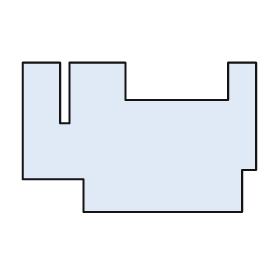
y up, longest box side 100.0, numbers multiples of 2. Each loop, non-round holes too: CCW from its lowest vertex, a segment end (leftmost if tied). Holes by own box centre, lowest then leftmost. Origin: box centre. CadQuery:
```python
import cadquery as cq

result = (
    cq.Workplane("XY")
    .moveTo(-24.0, -32.0)
    .lineTo(44.0, -32.0)
    .lineTo(44.0, -14.0)
    .lineTo(50.0, -14.0)
    .lineTo(50.0, 32.0)
    .lineTo(38.0, 32.0)
    .lineTo(38.0, 16.0)
    .lineTo(-6.0, 16.0)
    .lineTo(-6.0, 32.0)
    .lineTo(-30.0, 32.0)
    .lineTo(-30.0, 6.0)
    .lineTo(-34.0, 6.0)
    .lineTo(-34.0, 32.0)
    .lineTo(-50.0, 32.0)
    .lineTo(-50.0, -18.0)
    .lineTo(-24.0, -18.0)
    .close()
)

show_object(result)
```